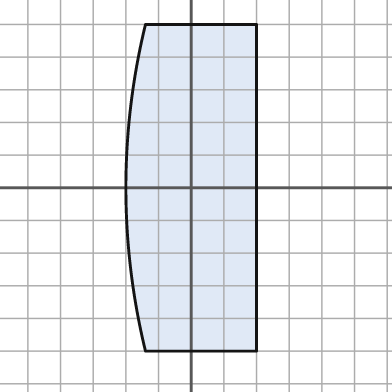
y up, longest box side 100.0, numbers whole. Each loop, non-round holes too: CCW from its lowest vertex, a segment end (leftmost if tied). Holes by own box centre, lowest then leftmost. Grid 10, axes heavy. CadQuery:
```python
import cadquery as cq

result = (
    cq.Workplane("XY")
    .moveTo(-14.0, -50.0)
    .lineTo(20.0, -50.0)
    .lineTo(20.0, 50.0)
    .lineTo(-14.0, 50.0)
    .threePointArc((-20.0, 0.0), (-14.0, -50.0))
    .close()
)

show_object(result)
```